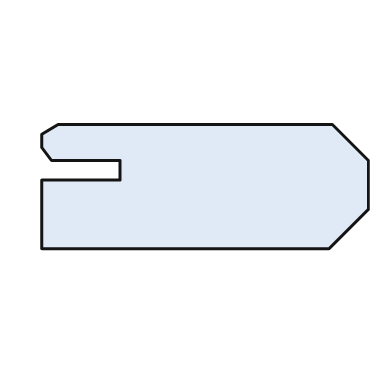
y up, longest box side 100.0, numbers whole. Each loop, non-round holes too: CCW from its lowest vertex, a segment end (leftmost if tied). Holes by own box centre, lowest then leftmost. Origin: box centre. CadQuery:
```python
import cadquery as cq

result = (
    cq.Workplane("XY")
    .moveTo(-50.0, -19.0)
    .lineTo(38.0, -19.0)
    .lineTo(50.0, -7.0)
    .lineTo(50.0, 8.0)
    .lineTo(39.0, 19.0)
    .lineTo(-45.0, 19.0)
    .lineTo(-50.0, 16.0)
    .lineTo(-50.0, 12.0)
    .lineTo(-47.0, 8.0)
    .lineTo(-26.0, 8.0)
    .lineTo(-26.0, 2.0)
    .lineTo(-50.0, 2.0)
    .close()
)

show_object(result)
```